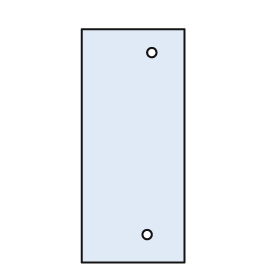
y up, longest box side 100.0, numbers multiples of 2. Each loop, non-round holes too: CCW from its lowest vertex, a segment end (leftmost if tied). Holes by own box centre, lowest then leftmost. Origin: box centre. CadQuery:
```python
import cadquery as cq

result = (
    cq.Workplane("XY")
    .moveTo(-22.0, -50.0)
    .lineTo(22.0, -50.0)
    .lineTo(22.0, 50.0)
    .lineTo(-22.0, 50.0)
    .close()
    .moveTo(6.0, -38.0)
    .circle(2.0)
    .moveTo(8.0, 40.0)
    .circle(2.0)
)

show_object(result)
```